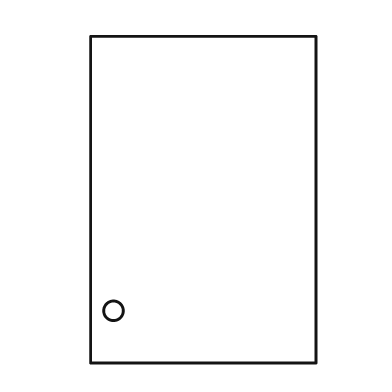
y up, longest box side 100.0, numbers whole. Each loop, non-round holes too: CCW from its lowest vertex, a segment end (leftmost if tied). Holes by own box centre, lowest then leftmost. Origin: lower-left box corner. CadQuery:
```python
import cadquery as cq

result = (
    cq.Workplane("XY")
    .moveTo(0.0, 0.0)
    .lineTo(69.0, 0.0)
    .lineTo(69.0, 100.0)
    .lineTo(0.0, 100.0)
    .close()
    .moveTo(7.0, 16.0)
    .circle(3.0)
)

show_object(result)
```